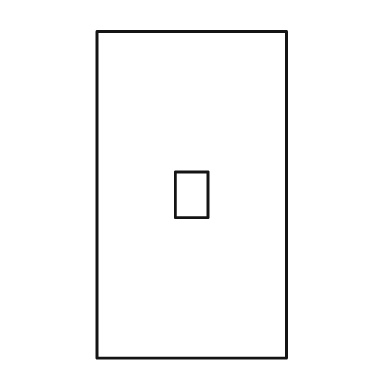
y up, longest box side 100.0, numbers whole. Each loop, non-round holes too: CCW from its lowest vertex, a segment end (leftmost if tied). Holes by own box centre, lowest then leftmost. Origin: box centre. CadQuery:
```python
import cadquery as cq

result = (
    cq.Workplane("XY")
    .moveTo(-29.0, -50.0)
    .lineTo(29.0, -50.0)
    .lineTo(29.0, 50.0)
    .lineTo(-29.0, 50.0)
    .close()
    .moveTo(-5.0, -7.0)
    .lineTo(5.0, -7.0)
    .lineTo(5.0, 7.0)
    .lineTo(-5.0, 7.0)
    .close()
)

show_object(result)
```